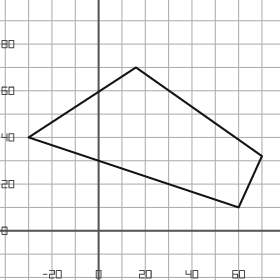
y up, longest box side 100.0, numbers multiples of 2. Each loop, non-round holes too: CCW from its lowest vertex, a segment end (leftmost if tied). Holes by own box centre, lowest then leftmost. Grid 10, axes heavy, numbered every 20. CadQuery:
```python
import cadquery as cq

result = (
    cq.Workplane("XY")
    .moveTo(60.0, 10.0)
    .lineTo(70.0, 32.0)
    .lineTo(16.0, 70.0)
    .lineTo(-30.0, 40.0)
    .close()
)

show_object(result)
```